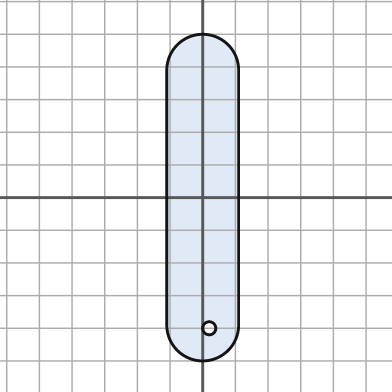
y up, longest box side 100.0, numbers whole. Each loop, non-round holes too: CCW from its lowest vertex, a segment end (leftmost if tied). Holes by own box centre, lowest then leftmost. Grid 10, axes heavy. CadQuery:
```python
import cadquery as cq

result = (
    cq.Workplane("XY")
    .moveTo(-11.0, -39.0)
    .threePointArc((0.0, -50.0), (11.0, -39.0))
    .lineTo(11.0, 39.0)
    .threePointArc((0.0, 50.0), (-11.0, 39.0))
    .close()
    .moveTo(2.0, -40.0)
    .circle(2.0)
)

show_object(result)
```